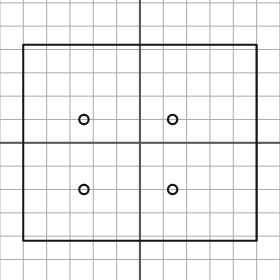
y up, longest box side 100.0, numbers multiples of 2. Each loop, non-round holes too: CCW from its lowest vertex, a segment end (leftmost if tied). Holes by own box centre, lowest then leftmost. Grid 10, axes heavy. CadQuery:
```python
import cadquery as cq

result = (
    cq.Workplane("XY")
    .moveTo(-50.0, -42.0)
    .lineTo(50.0, -42.0)
    .lineTo(50.0, 42.0)
    .lineTo(-50.0, 42.0)
    .close()
    .moveTo(-24.0, -20.0)
    .circle(2.0)
    .moveTo(14.0, -20.0)
    .circle(2.0)
    .moveTo(-24.0, 10.0)
    .circle(2.0)
    .moveTo(14.0, 10.0)
    .circle(2.0)
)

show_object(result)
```